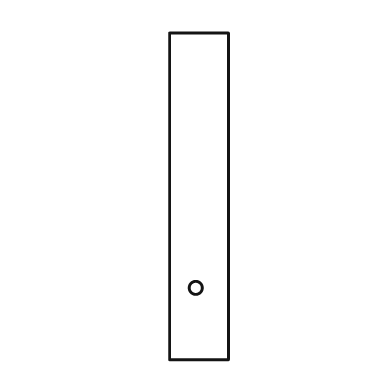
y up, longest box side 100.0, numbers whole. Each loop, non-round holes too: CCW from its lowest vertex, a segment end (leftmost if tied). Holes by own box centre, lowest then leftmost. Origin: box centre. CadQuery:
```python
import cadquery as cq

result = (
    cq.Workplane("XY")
    .moveTo(-9.0, -50.0)
    .lineTo(9.0, -50.0)
    .lineTo(9.0, 50.0)
    .lineTo(-9.0, 50.0)
    .close()
    .moveTo(-1.0, -28.0)
    .circle(2.0)
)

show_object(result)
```